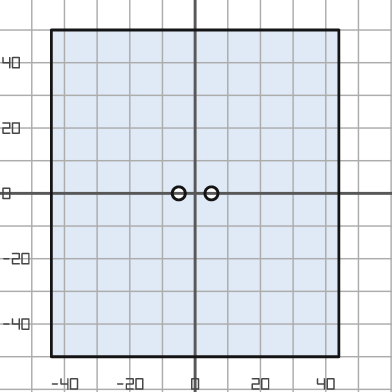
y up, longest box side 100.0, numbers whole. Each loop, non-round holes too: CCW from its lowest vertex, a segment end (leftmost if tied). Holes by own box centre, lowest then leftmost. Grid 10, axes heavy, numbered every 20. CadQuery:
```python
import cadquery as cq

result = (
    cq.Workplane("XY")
    .moveTo(-44.0, -50.0)
    .lineTo(44.0, -50.0)
    .lineTo(44.0, 50.0)
    .lineTo(-44.0, 50.0)
    .close()
    .moveTo(-5.0, 0.0)
    .circle(2.0)
    .moveTo(5.0, 0.0)
    .circle(2.0)
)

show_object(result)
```